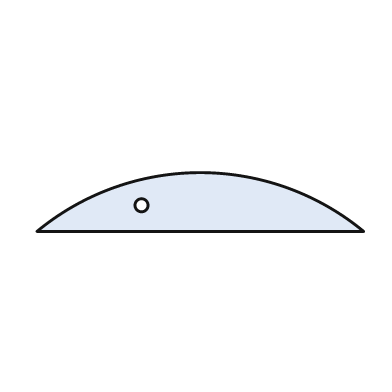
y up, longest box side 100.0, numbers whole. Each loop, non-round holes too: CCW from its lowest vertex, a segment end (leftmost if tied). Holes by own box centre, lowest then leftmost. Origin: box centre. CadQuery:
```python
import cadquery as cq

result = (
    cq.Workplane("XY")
    .moveTo(-50.0, -9.0)
    .lineTo(50.0, -9.0)
    .threePointArc((0.0, 9.0), (-50.0, -9.0))
    .close()
    .moveTo(-18.0, -1.0)
    .circle(2.0)
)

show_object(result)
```